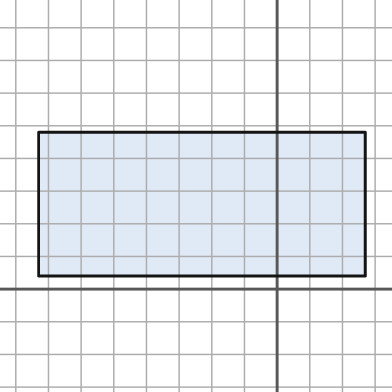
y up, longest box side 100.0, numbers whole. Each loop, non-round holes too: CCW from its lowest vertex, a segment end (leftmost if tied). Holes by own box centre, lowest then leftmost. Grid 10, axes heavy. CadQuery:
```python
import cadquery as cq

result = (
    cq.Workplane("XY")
    .moveTo(-73.0, 4.0)
    .lineTo(27.0, 4.0)
    .lineTo(27.0, 48.0)
    .lineTo(-73.0, 48.0)
    .close()
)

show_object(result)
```